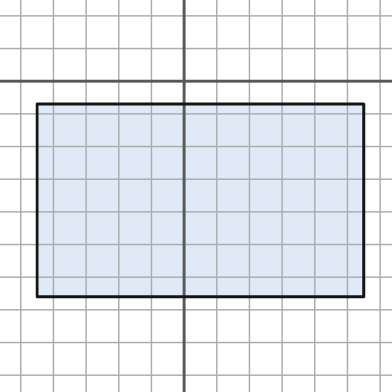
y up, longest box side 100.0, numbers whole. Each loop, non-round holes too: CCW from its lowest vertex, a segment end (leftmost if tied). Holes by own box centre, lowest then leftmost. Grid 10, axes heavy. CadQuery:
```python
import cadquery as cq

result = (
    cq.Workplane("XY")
    .moveTo(-45.0, -66.0)
    .lineTo(55.0, -66.0)
    .lineTo(55.0, -7.0)
    .lineTo(-45.0, -7.0)
    .close()
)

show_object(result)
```